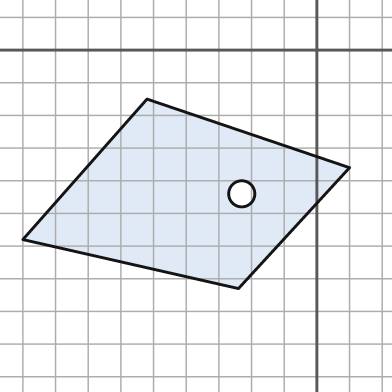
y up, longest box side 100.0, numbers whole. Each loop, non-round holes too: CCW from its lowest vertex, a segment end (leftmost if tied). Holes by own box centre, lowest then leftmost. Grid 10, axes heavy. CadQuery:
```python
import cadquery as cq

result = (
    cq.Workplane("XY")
    .moveTo(-24.0, -73.0)
    .lineTo(10.0, -36.0)
    .lineTo(-52.0, -15.0)
    .lineTo(-90.0, -58.0)
    .close()
    .moveTo(-23.0, -44.0)
    .circle(4.0)
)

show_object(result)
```